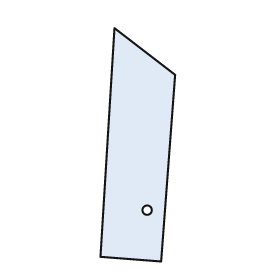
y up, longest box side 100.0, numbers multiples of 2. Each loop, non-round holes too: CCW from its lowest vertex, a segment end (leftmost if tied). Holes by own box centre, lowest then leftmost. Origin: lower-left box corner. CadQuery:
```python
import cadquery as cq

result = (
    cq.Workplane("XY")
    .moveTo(26.0, 0.0)
    .lineTo(32.0, 80.0)
    .lineTo(6.0, 100.0)
    .lineTo(0.0, 2.0)
    .close()
    .moveTo(20.0, 22.0)
    .circle(2.0)
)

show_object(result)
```